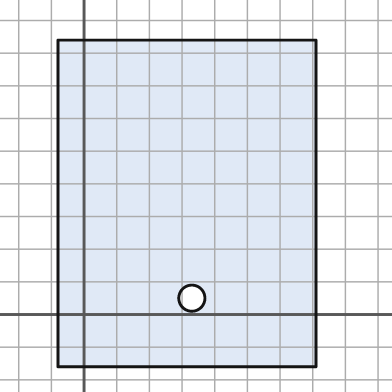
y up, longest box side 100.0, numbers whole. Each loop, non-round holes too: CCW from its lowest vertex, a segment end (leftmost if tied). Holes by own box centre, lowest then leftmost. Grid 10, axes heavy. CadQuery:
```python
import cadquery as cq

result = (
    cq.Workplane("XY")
    .moveTo(-8.0, -16.0)
    .lineTo(71.0, -16.0)
    .lineTo(71.0, 84.0)
    .lineTo(-8.0, 84.0)
    .close()
    .moveTo(33.0, 5.0)
    .circle(4.0)
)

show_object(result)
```